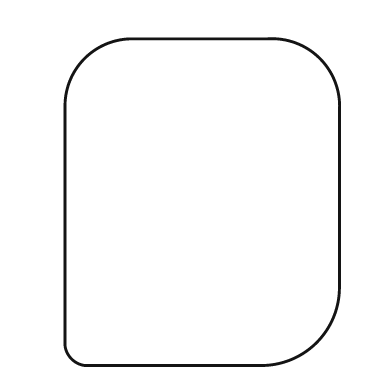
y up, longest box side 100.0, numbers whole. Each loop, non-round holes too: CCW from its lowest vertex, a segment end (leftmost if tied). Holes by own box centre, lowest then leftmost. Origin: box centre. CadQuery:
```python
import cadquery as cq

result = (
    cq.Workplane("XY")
    .moveTo(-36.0, -50.0)
    .lineTo(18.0, -50.0)
    .threePointArc((35.0, -43.0), (42.0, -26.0))
    .lineTo(42.0, 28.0)
    .threePointArc((36.0, 44.0), (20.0, 50.0))
    .lineTo(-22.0, 50.0)
    .threePointArc((-36.0, 44.0), (-42.0, 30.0))
    .lineTo(-42.0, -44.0)
    .threePointArc((-40.0, -48.0), (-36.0, -50.0))
    .close()
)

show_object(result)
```